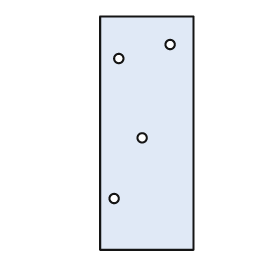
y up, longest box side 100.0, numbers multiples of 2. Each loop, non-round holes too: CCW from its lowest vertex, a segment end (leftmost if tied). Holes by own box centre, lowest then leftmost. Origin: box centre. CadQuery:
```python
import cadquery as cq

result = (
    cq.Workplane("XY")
    .moveTo(-20.0, -50.0)
    .lineTo(20.0, -50.0)
    .lineTo(20.0, 50.0)
    .lineTo(-20.0, 50.0)
    .close()
    .moveTo(-14.0, -28.0)
    .circle(2.0)
    .moveTo(-2.0, -2.0)
    .circle(2.0)
    .moveTo(-12.0, 32.0)
    .circle(2.0)
    .moveTo(10.0, 38.0)
    .circle(2.0)
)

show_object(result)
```